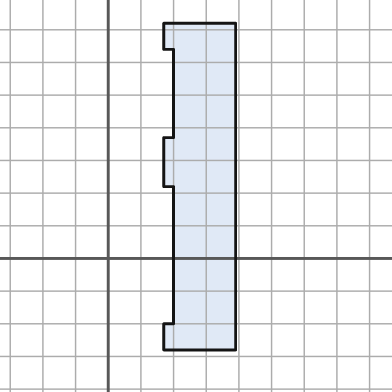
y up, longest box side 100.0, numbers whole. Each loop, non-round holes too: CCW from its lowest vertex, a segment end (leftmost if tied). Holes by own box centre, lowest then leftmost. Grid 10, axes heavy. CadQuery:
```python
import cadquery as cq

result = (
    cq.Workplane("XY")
    .moveTo(17.0, -28.0)
    .lineTo(39.0, -28.0)
    .lineTo(39.0, 72.0)
    .lineTo(17.0, 72.0)
    .lineTo(17.0, 64.0)
    .lineTo(20.0, 64.0)
    .lineTo(20.0, 37.0)
    .lineTo(17.0, 37.0)
    .lineTo(17.0, 22.0)
    .lineTo(20.0, 22.0)
    .lineTo(20.0, -20.0)
    .lineTo(17.0, -20.0)
    .close()
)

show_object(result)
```